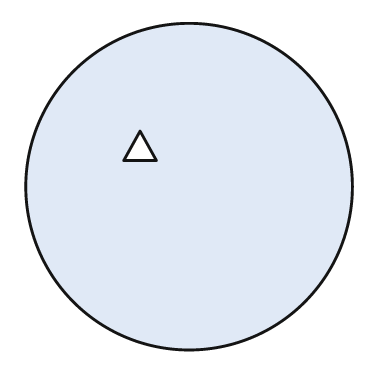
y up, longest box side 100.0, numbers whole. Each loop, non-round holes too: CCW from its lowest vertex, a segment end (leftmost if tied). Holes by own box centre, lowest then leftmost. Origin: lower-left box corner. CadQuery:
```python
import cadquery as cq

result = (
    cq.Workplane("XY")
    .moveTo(50.0, 50.0)
    .circle(50.0)
    .moveTo(30.0, 58.0)
    .lineTo(40.0, 58.0)
    .lineTo(35.0, 67.0)
    .close()
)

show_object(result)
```